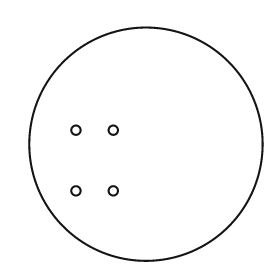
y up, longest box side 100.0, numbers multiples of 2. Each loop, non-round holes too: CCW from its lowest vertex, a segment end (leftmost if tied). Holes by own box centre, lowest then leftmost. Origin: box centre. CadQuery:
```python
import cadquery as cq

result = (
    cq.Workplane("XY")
    .moveTo(0.0, 0.0)
    .circle(50.0)
    .moveTo(-30.0, -20.0)
    .circle(2.0)
    .moveTo(-14.0, -20.0)
    .circle(2.0)
    .moveTo(-30.0, 6.0)
    .circle(2.0)
    .moveTo(-14.0, 6.0)
    .circle(2.0)
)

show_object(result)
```